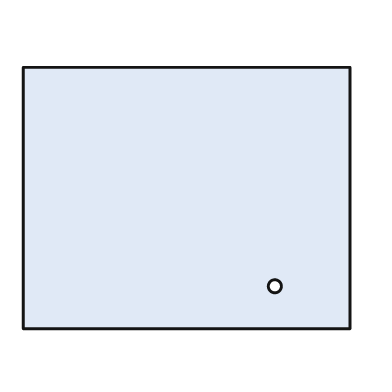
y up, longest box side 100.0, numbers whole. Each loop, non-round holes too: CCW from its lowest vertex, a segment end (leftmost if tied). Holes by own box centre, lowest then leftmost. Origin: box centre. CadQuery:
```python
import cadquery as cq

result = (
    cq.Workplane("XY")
    .moveTo(-50.0, -40.0)
    .lineTo(50.0, -40.0)
    .lineTo(50.0, 40.0)
    .lineTo(-50.0, 40.0)
    .close()
    .moveTo(27.0, -27.0)
    .circle(2.0)
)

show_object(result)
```